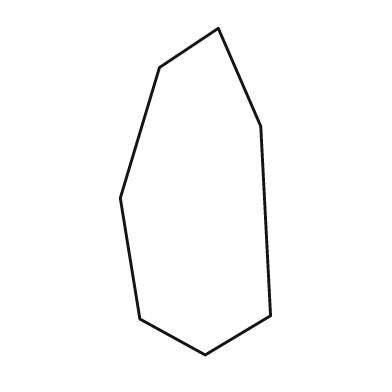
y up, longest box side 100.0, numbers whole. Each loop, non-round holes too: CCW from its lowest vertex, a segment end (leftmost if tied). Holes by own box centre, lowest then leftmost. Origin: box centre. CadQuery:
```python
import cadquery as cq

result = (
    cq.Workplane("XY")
    .moveTo(3.0, -50.0)
    .lineTo(23.0, -38.0)
    .lineTo(20.0, 20.0)
    .lineTo(7.0, 50.0)
    .lineTo(-11.0, 38.0)
    .lineTo(-23.0, -2.0)
    .lineTo(-17.0, -39.0)
    .close()
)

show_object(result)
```